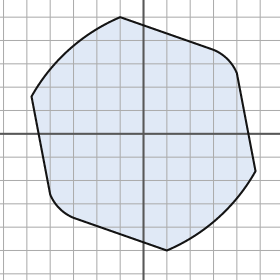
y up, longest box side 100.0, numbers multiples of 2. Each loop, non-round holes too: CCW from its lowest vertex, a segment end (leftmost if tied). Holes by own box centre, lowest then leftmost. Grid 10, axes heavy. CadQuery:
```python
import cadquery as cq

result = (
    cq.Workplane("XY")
    .moveTo(10.0, -50.0)
    .threePointArc((32.0, -36.0), (48.0, -16.0))
    .lineTo(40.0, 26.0)
    .threePointArc((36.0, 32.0), (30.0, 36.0))
    .lineTo(-10.0, 50.0)
    .threePointArc((-32.0, 36.0), (-48.0, 16.0))
    .lineTo(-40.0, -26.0)
    .threePointArc((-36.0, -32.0), (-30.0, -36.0))
    .close()
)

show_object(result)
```